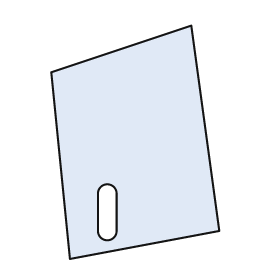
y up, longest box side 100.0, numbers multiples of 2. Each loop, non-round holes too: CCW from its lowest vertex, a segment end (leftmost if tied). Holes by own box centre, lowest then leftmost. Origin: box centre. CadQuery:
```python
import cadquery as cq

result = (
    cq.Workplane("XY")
    .moveTo(-28.0, -50.0)
    .lineTo(36.0, -38.0)
    .lineTo(24.0, 50.0)
    .lineTo(-36.0, 30.0)
    .close()
    .moveTo(-16.0, -38.0)
    .threePointArc((-12.0, -42.0), (-8.0, -38.0))
    .lineTo(-8.0, -22.0)
    .threePointArc((-12.0, -18.0), (-16.0, -22.0))
    .close()
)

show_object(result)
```